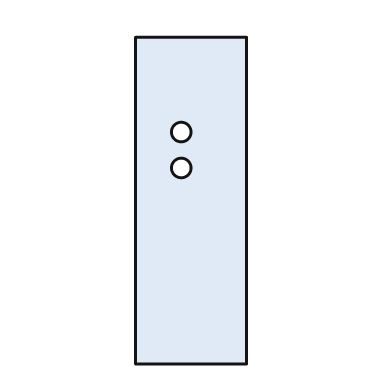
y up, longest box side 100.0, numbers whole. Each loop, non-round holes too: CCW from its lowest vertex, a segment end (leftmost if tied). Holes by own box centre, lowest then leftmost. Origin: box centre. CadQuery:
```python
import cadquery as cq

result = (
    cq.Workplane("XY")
    .moveTo(-17.0, -50.0)
    .lineTo(17.0, -50.0)
    .lineTo(17.0, 50.0)
    .lineTo(-17.0, 50.0)
    .close()
    .moveTo(-3.0, 10.0)
    .circle(3.0)
    .moveTo(-3.0, 21.0)
    .circle(3.0)
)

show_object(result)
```